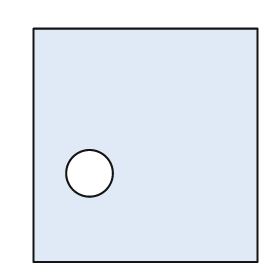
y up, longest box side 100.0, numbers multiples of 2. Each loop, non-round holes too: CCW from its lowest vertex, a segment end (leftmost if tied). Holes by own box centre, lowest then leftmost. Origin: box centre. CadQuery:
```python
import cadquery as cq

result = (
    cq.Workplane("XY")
    .moveTo(-48.0, -50.0)
    .lineTo(48.0, -50.0)
    .lineTo(48.0, 50.0)
    .lineTo(-48.0, 50.0)
    .close()
    .moveTo(-24.0, -12.0)
    .circle(10.0)
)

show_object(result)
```